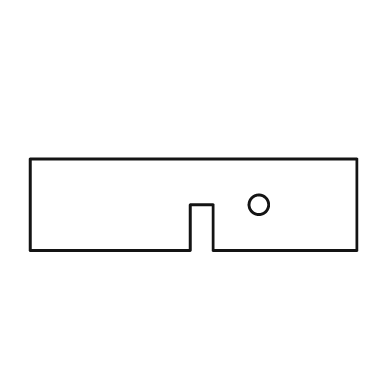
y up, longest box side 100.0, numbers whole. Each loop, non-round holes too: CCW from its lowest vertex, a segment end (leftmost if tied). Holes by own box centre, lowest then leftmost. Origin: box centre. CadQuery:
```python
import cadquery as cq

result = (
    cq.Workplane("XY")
    .moveTo(-50.0, -14.0)
    .lineTo(-1.0, -14.0)
    .lineTo(-1.0, 0.0)
    .lineTo(6.0, 0.0)
    .lineTo(6.0, -14.0)
    .lineTo(50.0, -14.0)
    .lineTo(50.0, 14.0)
    .lineTo(-50.0, 14.0)
    .close()
    .moveTo(20.0, 0.0)
    .circle(3.0)
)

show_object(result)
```